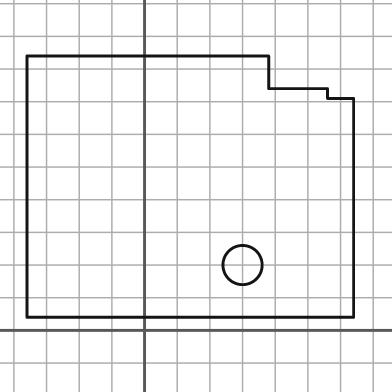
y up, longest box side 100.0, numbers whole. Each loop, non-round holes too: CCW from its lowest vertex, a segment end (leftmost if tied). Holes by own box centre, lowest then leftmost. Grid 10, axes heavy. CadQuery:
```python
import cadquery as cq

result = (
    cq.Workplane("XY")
    .moveTo(-36.0, 4.0)
    .lineTo(64.0, 4.0)
    .lineTo(64.0, 71.0)
    .lineTo(56.0, 71.0)
    .lineTo(56.0, 74.0)
    .lineTo(38.0, 74.0)
    .lineTo(38.0, 84.0)
    .lineTo(-36.0, 84.0)
    .close()
    .moveTo(30.0, 20.0)
    .circle(6.0)
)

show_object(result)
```